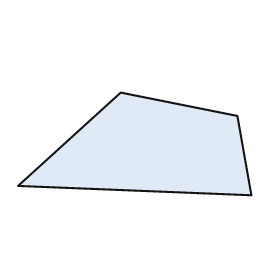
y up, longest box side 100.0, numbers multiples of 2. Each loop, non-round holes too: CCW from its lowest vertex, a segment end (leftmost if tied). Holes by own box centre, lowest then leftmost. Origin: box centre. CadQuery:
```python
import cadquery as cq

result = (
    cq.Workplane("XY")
    .moveTo(50.0, -22.0)
    .lineTo(44.0, 12.0)
    .lineTo(-6.0, 22.0)
    .lineTo(-50.0, -18.0)
    .close()
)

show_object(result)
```